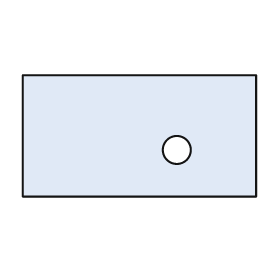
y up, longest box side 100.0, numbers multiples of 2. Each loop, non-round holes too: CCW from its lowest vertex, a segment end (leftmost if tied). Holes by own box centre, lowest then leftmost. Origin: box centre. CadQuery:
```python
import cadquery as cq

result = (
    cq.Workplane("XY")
    .moveTo(-50.0, -26.0)
    .lineTo(50.0, -26.0)
    .lineTo(50.0, 26.0)
    .lineTo(-50.0, 26.0)
    .close()
    .moveTo(16.0, -6.0)
    .circle(6.0)
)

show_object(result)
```